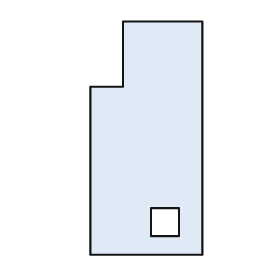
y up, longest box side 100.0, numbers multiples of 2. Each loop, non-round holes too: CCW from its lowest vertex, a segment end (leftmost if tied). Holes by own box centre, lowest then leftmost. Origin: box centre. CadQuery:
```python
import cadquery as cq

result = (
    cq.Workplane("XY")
    .moveTo(-24.0, -50.0)
    .lineTo(24.0, -50.0)
    .lineTo(24.0, 50.0)
    .lineTo(-10.0, 50.0)
    .lineTo(-10.0, 22.0)
    .lineTo(-24.0, 22.0)
    .close()
    .moveTo(2.0, -42.0)
    .lineTo(14.0, -42.0)
    .lineTo(14.0, -30.0)
    .lineTo(2.0, -30.0)
    .close()
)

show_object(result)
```